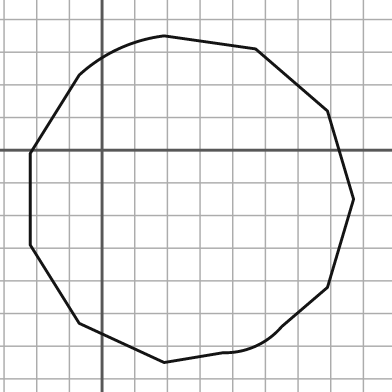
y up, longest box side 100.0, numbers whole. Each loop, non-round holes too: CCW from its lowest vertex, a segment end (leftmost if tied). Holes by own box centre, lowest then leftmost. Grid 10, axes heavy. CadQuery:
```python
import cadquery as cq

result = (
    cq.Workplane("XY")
    .moveTo(19.0, -65.0)
    .lineTo(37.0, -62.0)
    .threePointArc((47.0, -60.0), (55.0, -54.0))
    .lineTo(69.0, -42.0)
    .lineTo(77.0, -15.0)
    .lineTo(69.0, 12.0)
    .lineTo(47.0, 31.0)
    .lineTo(19.0, 35.0)
    .threePointArc((5.0, 31.0), (-7.0, 23.0))
    .lineTo(-22.0, -1.0)
    .lineTo(-22.0, -29.0)
    .lineTo(-7.0, -53.0)
    .close()
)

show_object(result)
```